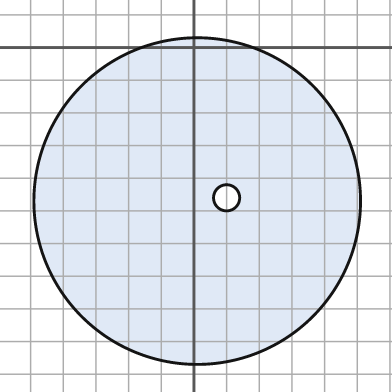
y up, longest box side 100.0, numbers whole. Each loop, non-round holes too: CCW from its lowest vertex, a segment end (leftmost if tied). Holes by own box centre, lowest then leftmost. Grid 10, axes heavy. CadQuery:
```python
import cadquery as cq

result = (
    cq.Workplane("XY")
    .moveTo(1.0, -47.0)
    .circle(50.0)
    .moveTo(10.0, -46.0)
    .circle(4.0)
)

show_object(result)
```